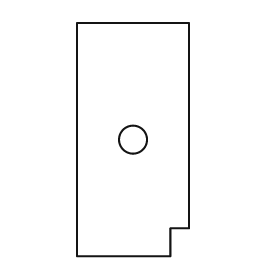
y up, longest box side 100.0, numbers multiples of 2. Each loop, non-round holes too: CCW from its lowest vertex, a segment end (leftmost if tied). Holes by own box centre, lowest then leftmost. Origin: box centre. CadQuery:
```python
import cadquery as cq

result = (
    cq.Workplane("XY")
    .moveTo(-24.0, -50.0)
    .lineTo(16.0, -50.0)
    .lineTo(16.0, -38.0)
    .lineTo(24.0, -38.0)
    .lineTo(24.0, 50.0)
    .lineTo(-24.0, 50.0)
    .close()
    .moveTo(0.0, 0.0)
    .circle(6.0)
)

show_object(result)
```